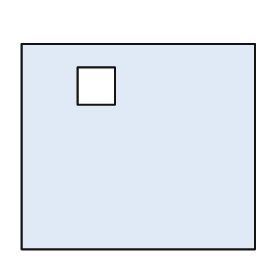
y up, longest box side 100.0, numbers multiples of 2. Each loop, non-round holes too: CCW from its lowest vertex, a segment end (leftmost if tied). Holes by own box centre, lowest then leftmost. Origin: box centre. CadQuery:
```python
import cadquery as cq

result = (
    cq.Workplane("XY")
    .moveTo(-50.0, -44.0)
    .lineTo(50.0, -44.0)
    .lineTo(50.0, 44.0)
    .lineTo(-50.0, 44.0)
    .close()
    .moveTo(-26.0, 18.0)
    .lineTo(-10.0, 18.0)
    .lineTo(-10.0, 34.0)
    .lineTo(-26.0, 34.0)
    .close()
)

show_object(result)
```